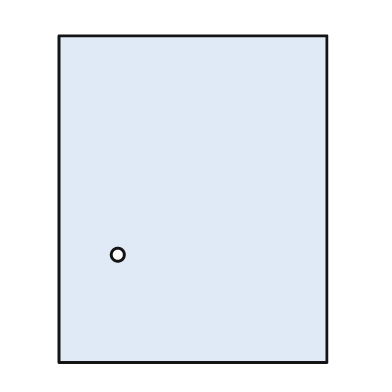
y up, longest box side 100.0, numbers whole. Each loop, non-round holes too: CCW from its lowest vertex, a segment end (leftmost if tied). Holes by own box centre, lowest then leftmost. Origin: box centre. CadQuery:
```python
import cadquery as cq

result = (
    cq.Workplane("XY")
    .moveTo(-41.0, -50.0)
    .lineTo(41.0, -50.0)
    .lineTo(41.0, 50.0)
    .lineTo(-41.0, 50.0)
    .close()
    .moveTo(-23.0, -17.0)
    .circle(2.0)
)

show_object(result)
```